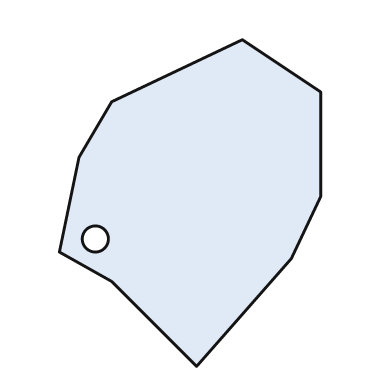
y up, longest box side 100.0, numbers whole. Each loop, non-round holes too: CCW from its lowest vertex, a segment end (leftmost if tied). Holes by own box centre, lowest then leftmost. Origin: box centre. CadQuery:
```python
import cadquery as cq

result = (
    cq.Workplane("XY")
    .moveTo(2.0, -50.0)
    .lineTo(31.0, -17.0)
    .lineTo(40.0, 2.0)
    .lineTo(40.0, 34.0)
    .lineTo(16.0, 50.0)
    .lineTo(-24.0, 31.0)
    .lineTo(-34.0, 14.0)
    .lineTo(-40.0, -15.0)
    .lineTo(-24.0, -24.0)
    .close()
    .moveTo(-29.0, -11.0)
    .circle(4.0)
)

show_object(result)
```